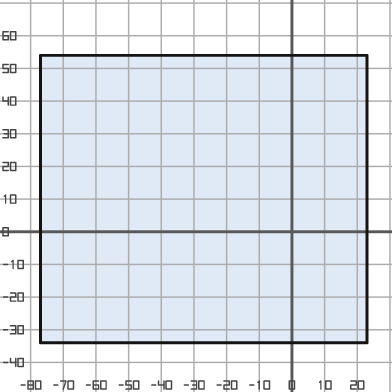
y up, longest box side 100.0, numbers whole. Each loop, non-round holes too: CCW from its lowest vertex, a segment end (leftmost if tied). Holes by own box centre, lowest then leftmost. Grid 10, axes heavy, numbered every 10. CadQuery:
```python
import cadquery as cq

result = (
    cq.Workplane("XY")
    .moveTo(-77.0, -34.0)
    .lineTo(23.0, -34.0)
    .lineTo(23.0, 54.0)
    .lineTo(-77.0, 54.0)
    .close()
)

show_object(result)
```